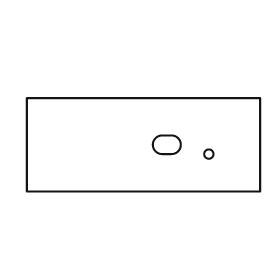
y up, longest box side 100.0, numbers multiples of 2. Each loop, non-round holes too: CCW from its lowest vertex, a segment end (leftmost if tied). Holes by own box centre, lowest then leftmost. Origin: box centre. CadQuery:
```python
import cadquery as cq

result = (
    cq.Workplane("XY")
    .moveTo(-50.0, -20.0)
    .lineTo(50.0, -20.0)
    .lineTo(50.0, 20.0)
    .lineTo(-50.0, 20.0)
    .close()
    .moveTo(28.0, -4.0)
    .circle(2.0)
    .moveTo(8.0, -4.0)
    .lineTo(12.0, -4.0)
    .threePointArc((16.0, 0.0), (12.0, 4.0))
    .lineTo(8.0, 4.0)
    .threePointArc((4.0, 0.0), (8.0, -4.0))
    .close()
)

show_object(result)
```